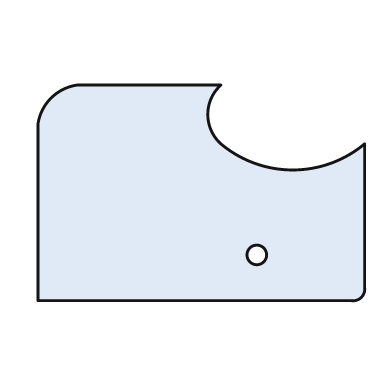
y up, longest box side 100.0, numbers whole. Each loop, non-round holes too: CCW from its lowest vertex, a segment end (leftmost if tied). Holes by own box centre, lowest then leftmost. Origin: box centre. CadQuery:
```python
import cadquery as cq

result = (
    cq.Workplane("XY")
    .moveTo(-50.0, -33.0)
    .lineTo(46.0, -33.0)
    .threePointArc((49.0, -32.0), (50.0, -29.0))
    .lineTo(50.0, 15.0)
    .threePointArc((28.0, 7.0), (6.0, 15.0))
    .threePointArc((2.0, 24.0), (6.0, 33.0))
    .lineTo(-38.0, 33.0)
    .threePointArc((-46.0, 29.0), (-50.0, 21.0))
    .close()
    .moveTo(17.0, -19.0)
    .circle(3.0)
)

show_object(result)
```